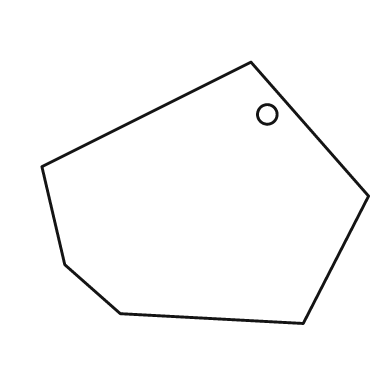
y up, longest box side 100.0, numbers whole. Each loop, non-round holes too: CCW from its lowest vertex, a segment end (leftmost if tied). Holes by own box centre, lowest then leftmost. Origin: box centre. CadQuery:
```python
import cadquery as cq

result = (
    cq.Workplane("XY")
    .moveTo(30.0, -40.0)
    .lineTo(50.0, -1.0)
    .lineTo(14.0, 40.0)
    .lineTo(-50.0, 8.0)
    .lineTo(-43.0, -22.0)
    .lineTo(-26.0, -37.0)
    .close()
    .moveTo(19.0, 24.0)
    .circle(3.0)
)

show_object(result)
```